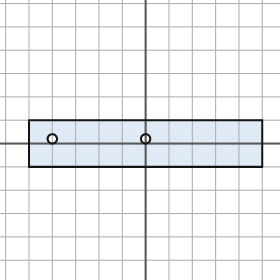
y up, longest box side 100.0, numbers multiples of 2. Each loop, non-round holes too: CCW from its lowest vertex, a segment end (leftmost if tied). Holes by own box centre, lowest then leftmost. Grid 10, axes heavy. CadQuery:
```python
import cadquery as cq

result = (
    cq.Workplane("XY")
    .moveTo(-50.0, -10.0)
    .lineTo(50.0, -10.0)
    .lineTo(50.0, 10.0)
    .lineTo(-50.0, 10.0)
    .close()
    .moveTo(-40.0, 2.0)
    .circle(2.0)
    .moveTo(0.0, 2.0)
    .circle(2.0)
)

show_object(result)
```